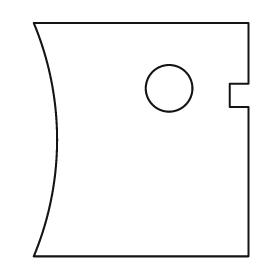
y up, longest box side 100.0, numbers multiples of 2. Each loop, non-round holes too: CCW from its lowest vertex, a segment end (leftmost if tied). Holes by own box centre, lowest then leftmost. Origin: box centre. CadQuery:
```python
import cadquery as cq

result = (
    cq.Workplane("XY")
    .moveTo(-46.0, -50.0)
    .lineTo(46.0, -50.0)
    .lineTo(46.0, 14.0)
    .lineTo(38.0, 14.0)
    .lineTo(38.0, 24.0)
    .lineTo(46.0, 24.0)
    .lineTo(46.0, 50.0)
    .lineTo(-46.0, 50.0)
    .threePointArc((-36.0, 0.0), (-46.0, -50.0))
    .close()
    .moveTo(12.0, 22.0)
    .circle(10.0)
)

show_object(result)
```